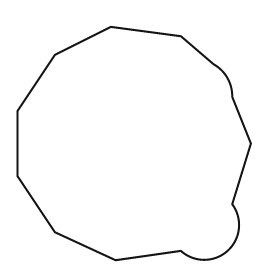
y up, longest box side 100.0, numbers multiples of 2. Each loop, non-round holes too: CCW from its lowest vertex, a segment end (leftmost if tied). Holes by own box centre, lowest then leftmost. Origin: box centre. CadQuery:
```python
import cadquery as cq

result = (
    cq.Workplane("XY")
    .moveTo(-8.0, -50.0)
    .lineTo(20.0, -46.0)
    .threePointArc((40.0, -46.0), (42.0, -26.0))
    .lineTo(50.0, 0.0)
    .lineTo(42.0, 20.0)
    .threePointArc((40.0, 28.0), (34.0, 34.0))
    .lineTo(20.0, 46.0)
    .lineTo(-10.0, 50.0)
    .lineTo(-34.0, 38.0)
    .lineTo(-50.0, 14.0)
    .lineTo(-50.0, -14.0)
    .lineTo(-34.0, -38.0)
    .close()
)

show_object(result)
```